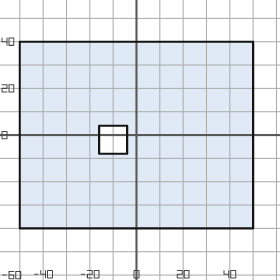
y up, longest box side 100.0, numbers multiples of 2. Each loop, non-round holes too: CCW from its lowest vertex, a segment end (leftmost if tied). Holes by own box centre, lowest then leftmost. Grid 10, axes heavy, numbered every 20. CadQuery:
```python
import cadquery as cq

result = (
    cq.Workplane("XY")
    .moveTo(-50.0, -40.0)
    .lineTo(50.0, -40.0)
    .lineTo(50.0, 40.0)
    .lineTo(-50.0, 40.0)
    .close()
    .moveTo(-16.0, -8.0)
    .lineTo(-4.0, -8.0)
    .lineTo(-4.0, 4.0)
    .lineTo(-16.0, 4.0)
    .close()
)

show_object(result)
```